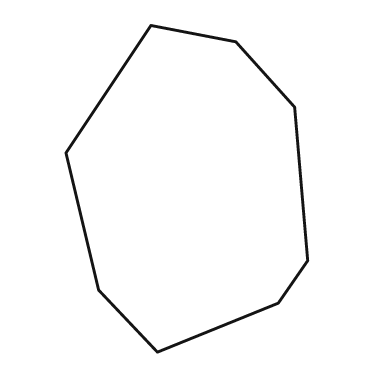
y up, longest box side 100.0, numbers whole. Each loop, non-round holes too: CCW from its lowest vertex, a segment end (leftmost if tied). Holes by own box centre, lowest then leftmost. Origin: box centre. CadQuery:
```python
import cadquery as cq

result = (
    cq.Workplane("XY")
    .moveTo(-9.0, -50.0)
    .lineTo(28.0, -35.0)
    .lineTo(37.0, -22.0)
    .lineTo(33.0, 25.0)
    .lineTo(15.0, 45.0)
    .lineTo(-11.0, 50.0)
    .lineTo(-37.0, 11.0)
    .lineTo(-27.0, -31.0)
    .close()
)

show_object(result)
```